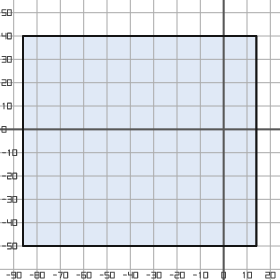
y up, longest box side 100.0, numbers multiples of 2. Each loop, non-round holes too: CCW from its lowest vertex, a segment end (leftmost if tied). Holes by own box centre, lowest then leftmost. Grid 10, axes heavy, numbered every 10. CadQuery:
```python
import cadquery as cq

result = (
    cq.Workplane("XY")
    .moveTo(-86.0, -50.0)
    .lineTo(14.0, -50.0)
    .lineTo(14.0, 40.0)
    .lineTo(-86.0, 40.0)
    .close()
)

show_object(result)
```